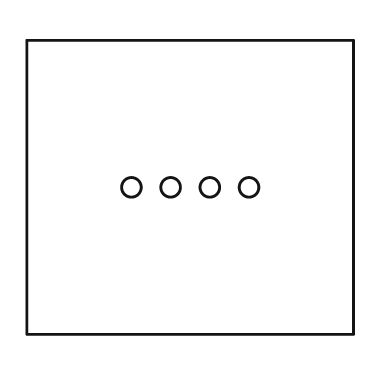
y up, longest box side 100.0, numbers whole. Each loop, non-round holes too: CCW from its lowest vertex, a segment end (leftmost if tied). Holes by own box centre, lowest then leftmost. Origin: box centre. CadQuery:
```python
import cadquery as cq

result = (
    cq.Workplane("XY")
    .moveTo(-50.0, -45.0)
    .lineTo(50.0, -45.0)
    .lineTo(50.0, 45.0)
    .lineTo(-50.0, 45.0)
    .close()
    .moveTo(-18.0, 0.0)
    .circle(3.0)
    .moveTo(-6.0, 0.0)
    .circle(3.0)
    .moveTo(6.0, 0.0)
    .circle(3.0)
    .moveTo(18.0, 0.0)
    .circle(3.0)
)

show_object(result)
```